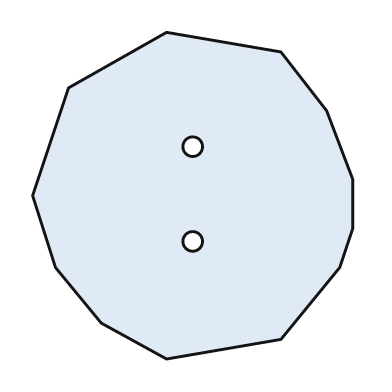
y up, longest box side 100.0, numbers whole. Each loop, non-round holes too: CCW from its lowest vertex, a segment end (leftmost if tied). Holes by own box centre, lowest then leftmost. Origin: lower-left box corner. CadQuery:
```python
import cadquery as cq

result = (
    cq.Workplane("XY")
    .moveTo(41.0, 0.0)
    .lineTo(76.0, 6.0)
    .lineTo(94.0, 28.0)
    .lineTo(98.0, 40.0)
    .lineTo(98.0, 55.0)
    .lineTo(90.0, 76.0)
    .lineTo(76.0, 94.0)
    .lineTo(41.0, 100.0)
    .lineTo(11.0, 83.0)
    .lineTo(0.0, 50.0)
    .lineTo(7.0, 28.0)
    .lineTo(21.0, 11.0)
    .close()
    .moveTo(49.0, 36.0)
    .circle(3.0)
    .moveTo(49.0, 65.0)
    .circle(3.0)
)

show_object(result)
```